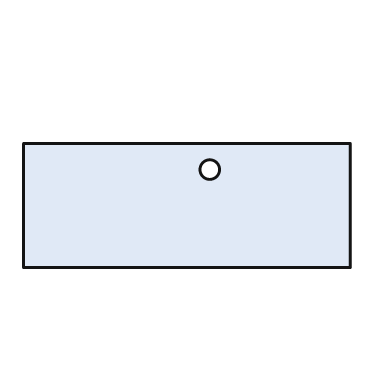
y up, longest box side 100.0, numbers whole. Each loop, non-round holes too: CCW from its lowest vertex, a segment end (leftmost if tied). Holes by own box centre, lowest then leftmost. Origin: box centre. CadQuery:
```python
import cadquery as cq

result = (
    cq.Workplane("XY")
    .moveTo(-50.0, -19.0)
    .lineTo(50.0, -19.0)
    .lineTo(50.0, 19.0)
    .lineTo(-50.0, 19.0)
    .close()
    .moveTo(7.0, 11.0)
    .circle(3.0)
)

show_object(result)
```